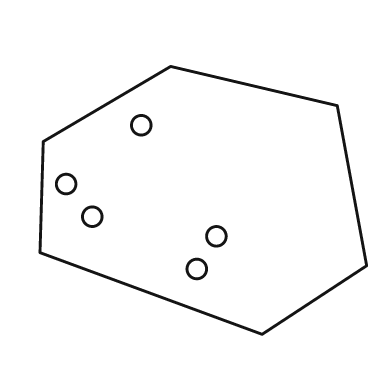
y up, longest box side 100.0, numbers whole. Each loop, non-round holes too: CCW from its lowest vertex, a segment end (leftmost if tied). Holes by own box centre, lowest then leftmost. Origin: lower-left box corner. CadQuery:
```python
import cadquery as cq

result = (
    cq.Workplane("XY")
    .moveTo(68.0, 0.0)
    .lineTo(100.0, 21.0)
    .lineTo(91.0, 70.0)
    .lineTo(40.0, 82.0)
    .lineTo(1.0, 59.0)
    .lineTo(0.0, 25.0)
    .close()
    .moveTo(48.0, 20.0)
    .circle(3.0)
    .moveTo(54.0, 30.0)
    .circle(3.0)
    .moveTo(16.0, 36.0)
    .circle(3.0)
    .moveTo(8.0, 46.0)
    .circle(3.0)
    .moveTo(31.0, 64.0)
    .circle(3.0)
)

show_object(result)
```